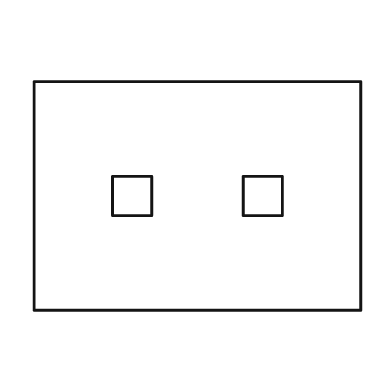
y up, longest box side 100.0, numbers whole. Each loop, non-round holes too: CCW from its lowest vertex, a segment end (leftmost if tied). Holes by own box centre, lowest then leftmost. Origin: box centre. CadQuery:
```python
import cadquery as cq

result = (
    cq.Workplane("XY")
    .moveTo(-50.0, -35.0)
    .lineTo(50.0, -35.0)
    .lineTo(50.0, 35.0)
    .lineTo(-50.0, 35.0)
    .close()
    .moveTo(-26.0, -6.0)
    .lineTo(-14.0, -6.0)
    .lineTo(-14.0, 6.0)
    .lineTo(-26.0, 6.0)
    .close()
    .moveTo(14.0, -6.0)
    .lineTo(26.0, -6.0)
    .lineTo(26.0, 6.0)
    .lineTo(14.0, 6.0)
    .close()
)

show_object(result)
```